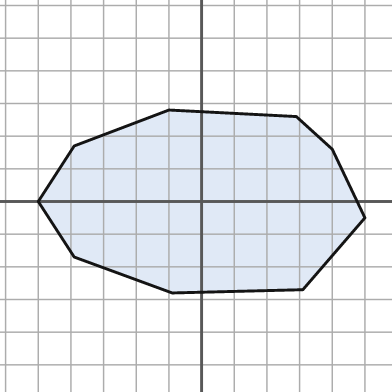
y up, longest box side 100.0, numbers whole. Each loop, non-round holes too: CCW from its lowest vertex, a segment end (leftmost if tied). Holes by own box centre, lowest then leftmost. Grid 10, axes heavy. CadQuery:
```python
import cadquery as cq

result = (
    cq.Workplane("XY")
    .moveTo(-9.0, -28.0)
    .lineTo(31.0, -27.0)
    .lineTo(50.0, -5.0)
    .lineTo(40.0, 16.0)
    .lineTo(29.0, 26.0)
    .lineTo(-10.0, 28.0)
    .lineTo(-39.0, 17.0)
    .lineTo(-50.0, 0.0)
    .lineTo(-39.0, -17.0)
    .close()
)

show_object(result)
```